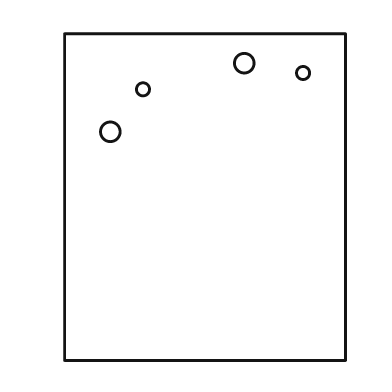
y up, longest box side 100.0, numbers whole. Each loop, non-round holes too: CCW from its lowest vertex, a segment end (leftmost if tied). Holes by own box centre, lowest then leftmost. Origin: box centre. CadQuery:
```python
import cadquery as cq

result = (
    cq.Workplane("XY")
    .moveTo(-43.0, -50.0)
    .lineTo(43.0, -50.0)
    .lineTo(43.0, 50.0)
    .lineTo(-43.0, 50.0)
    .close()
    .moveTo(-29.0, 20.0)
    .circle(3.0)
    .moveTo(-19.0, 33.0)
    .circle(2.0)
    .moveTo(30.0, 38.0)
    .circle(2.0)
    .moveTo(12.0, 41.0)
    .circle(3.0)
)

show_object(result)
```